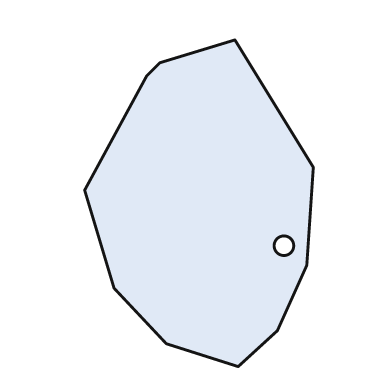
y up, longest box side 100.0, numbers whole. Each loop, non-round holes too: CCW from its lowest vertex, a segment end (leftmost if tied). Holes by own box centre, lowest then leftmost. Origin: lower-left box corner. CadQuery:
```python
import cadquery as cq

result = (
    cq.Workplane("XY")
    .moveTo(47.0, 0.0)
    .lineTo(59.0, 11.0)
    .lineTo(68.0, 31.0)
    .lineTo(70.0, 61.0)
    .lineTo(46.0, 100.0)
    .lineTo(23.0, 93.0)
    .lineTo(19.0, 89.0)
    .lineTo(0.0, 54.0)
    .lineTo(9.0, 24.0)
    .lineTo(25.0, 7.0)
    .close()
    .moveTo(61.0, 37.0)
    .circle(3.0)
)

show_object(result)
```